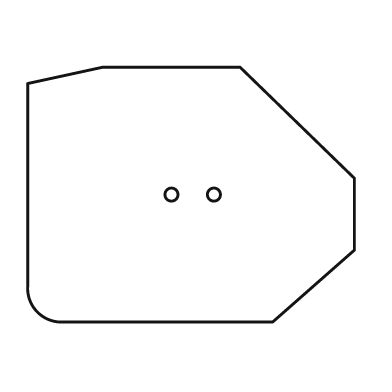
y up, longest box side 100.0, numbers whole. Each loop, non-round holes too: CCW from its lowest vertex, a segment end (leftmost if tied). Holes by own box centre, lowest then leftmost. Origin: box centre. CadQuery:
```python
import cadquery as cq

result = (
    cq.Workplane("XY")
    .moveTo(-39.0, -39.0)
    .lineTo(25.0, -39.0)
    .lineTo(50.0, -17.0)
    .lineTo(50.0, 5.0)
    .lineTo(15.0, 39.0)
    .lineTo(-27.0, 39.0)
    .lineTo(-50.0, 34.0)
    .lineTo(-50.0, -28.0)
    .threePointArc((-47.0, -36.0), (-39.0, -39.0))
    .close()
    .moveTo(-6.0, 0.0)
    .circle(2.0)
    .moveTo(7.0, 0.0)
    .circle(2.0)
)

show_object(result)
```